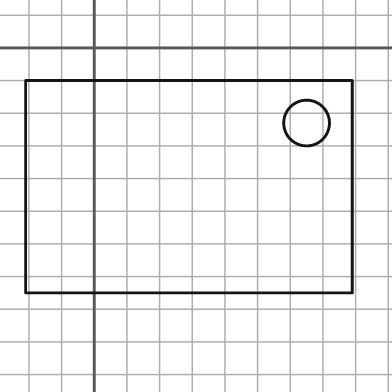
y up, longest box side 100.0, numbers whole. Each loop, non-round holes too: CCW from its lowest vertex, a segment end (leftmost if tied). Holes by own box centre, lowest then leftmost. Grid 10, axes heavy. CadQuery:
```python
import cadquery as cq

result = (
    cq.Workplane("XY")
    .moveTo(-21.0, -75.0)
    .lineTo(79.0, -75.0)
    .lineTo(79.0, -10.0)
    .lineTo(-21.0, -10.0)
    .close()
    .moveTo(65.0, -23.0)
    .circle(7.0)
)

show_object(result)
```